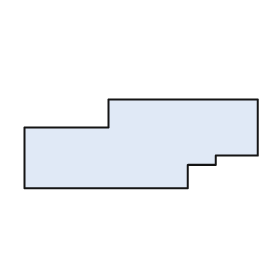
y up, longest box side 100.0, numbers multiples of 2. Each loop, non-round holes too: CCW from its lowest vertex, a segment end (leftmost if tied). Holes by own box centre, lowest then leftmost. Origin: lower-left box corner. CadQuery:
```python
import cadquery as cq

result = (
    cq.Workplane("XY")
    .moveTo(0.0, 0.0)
    .lineTo(70.0, 0.0)
    .lineTo(70.0, 10.0)
    .lineTo(82.0, 10.0)
    .lineTo(82.0, 14.0)
    .lineTo(100.0, 14.0)
    .lineTo(100.0, 38.0)
    .lineTo(36.0, 38.0)
    .lineTo(36.0, 26.0)
    .lineTo(0.0, 26.0)
    .close()
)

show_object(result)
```